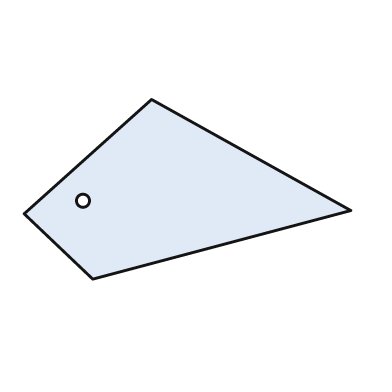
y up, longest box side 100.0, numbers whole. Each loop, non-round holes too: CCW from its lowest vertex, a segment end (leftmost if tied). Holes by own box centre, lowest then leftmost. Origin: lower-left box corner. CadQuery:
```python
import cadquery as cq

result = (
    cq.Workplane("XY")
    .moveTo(21.0, 0.0)
    .lineTo(100.0, 21.0)
    .lineTo(39.0, 55.0)
    .lineTo(0.0, 20.0)
    .close()
    .moveTo(18.0, 24.0)
    .circle(2.0)
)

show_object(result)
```